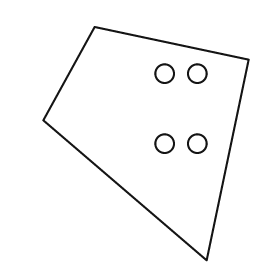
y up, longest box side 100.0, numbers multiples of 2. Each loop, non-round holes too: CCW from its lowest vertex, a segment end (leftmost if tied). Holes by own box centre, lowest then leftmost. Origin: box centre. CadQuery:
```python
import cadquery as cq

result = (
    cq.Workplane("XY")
    .moveTo(26.0, -50.0)
    .lineTo(44.0, 36.0)
    .lineTo(-22.0, 50.0)
    .lineTo(-44.0, 10.0)
    .close()
    .moveTo(8.0, 0.0)
    .circle(4.0)
    .moveTo(22.0, 0.0)
    .circle(4.0)
    .moveTo(8.0, 30.0)
    .circle(4.0)
    .moveTo(22.0, 30.0)
    .circle(4.0)
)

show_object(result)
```